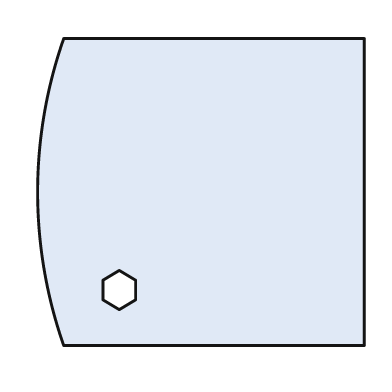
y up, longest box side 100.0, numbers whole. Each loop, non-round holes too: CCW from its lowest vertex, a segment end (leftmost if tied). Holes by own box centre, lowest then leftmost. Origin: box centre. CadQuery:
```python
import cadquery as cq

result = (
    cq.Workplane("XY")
    .moveTo(-42.0, -47.0)
    .lineTo(50.0, -47.0)
    .lineTo(50.0, 47.0)
    .lineTo(-42.0, 47.0)
    .threePointArc((-50.0, 0.0), (-42.0, -47.0))
    .close()
    .moveTo(-25.0, -36.0)
    .lineTo(-20.0, -33.0)
    .lineTo(-20.0, -27.0)
    .lineTo(-25.0, -24.0)
    .lineTo(-30.0, -27.0)
    .lineTo(-30.0, -33.0)
    .close()
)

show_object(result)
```